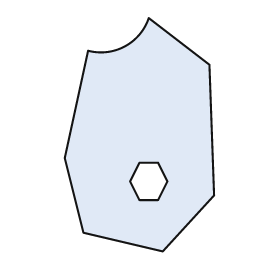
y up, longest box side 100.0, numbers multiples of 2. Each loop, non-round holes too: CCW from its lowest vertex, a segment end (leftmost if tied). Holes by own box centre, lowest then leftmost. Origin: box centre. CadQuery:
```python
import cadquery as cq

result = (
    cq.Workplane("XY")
    .moveTo(10.0, -50.0)
    .lineTo(32.0, -26.0)
    .lineTo(30.0, 30.0)
    .lineTo(4.0, 50.0)
    .threePointArc((-6.0, 38.0), (-22.0, 36.0))
    .lineTo(-32.0, -10.0)
    .lineTo(-24.0, -42.0)
    .close()
    .moveTo(0.0, -28.0)
    .lineTo(8.0, -28.0)
    .lineTo(12.0, -20.0)
    .lineTo(8.0, -12.0)
    .lineTo(0.0, -12.0)
    .lineTo(-4.0, -20.0)
    .close()
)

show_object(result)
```